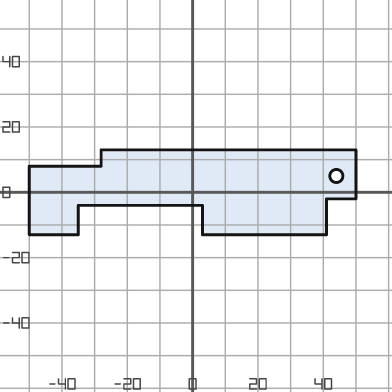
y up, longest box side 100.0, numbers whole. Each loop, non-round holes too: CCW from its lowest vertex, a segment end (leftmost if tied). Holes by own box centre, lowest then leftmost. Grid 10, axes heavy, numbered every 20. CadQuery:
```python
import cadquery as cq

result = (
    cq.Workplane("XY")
    .moveTo(-50.0, -13.0)
    .lineTo(-35.0, -13.0)
    .lineTo(-35.0, -4.0)
    .lineTo(3.0, -4.0)
    .lineTo(3.0, -13.0)
    .lineTo(41.0, -13.0)
    .lineTo(41.0, -2.0)
    .lineTo(50.0, -2.0)
    .lineTo(50.0, 13.0)
    .lineTo(-28.0, 13.0)
    .lineTo(-28.0, 8.0)
    .lineTo(-50.0, 8.0)
    .close()
    .moveTo(44.0, 5.0)
    .circle(2.0)
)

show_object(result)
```